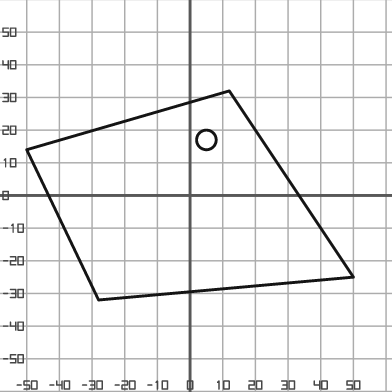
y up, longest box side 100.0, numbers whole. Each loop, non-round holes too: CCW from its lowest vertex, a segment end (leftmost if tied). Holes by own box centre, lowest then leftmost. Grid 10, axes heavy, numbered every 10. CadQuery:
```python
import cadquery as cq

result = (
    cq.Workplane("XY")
    .moveTo(-28.0, -32.0)
    .lineTo(50.0, -25.0)
    .lineTo(12.0, 32.0)
    .lineTo(-50.0, 14.0)
    .close()
    .moveTo(5.0, 17.0)
    .circle(3.0)
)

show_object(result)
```